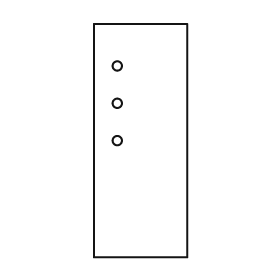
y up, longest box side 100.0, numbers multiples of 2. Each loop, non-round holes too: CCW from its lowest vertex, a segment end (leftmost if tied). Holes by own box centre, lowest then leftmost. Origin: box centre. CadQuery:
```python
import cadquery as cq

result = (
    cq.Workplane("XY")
    .moveTo(-20.0, -50.0)
    .lineTo(20.0, -50.0)
    .lineTo(20.0, 50.0)
    .lineTo(-20.0, 50.0)
    .close()
    .moveTo(-10.0, 0.0)
    .circle(2.0)
    .moveTo(-10.0, 16.0)
    .circle(2.0)
    .moveTo(-10.0, 32.0)
    .circle(2.0)
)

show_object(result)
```